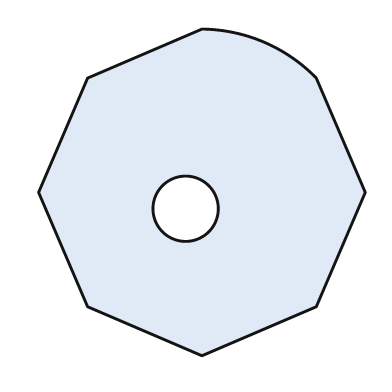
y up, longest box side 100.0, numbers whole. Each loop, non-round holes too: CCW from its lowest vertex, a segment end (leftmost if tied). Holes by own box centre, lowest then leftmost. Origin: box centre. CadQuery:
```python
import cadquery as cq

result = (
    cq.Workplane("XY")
    .moveTo(0.0, -50.0)
    .lineTo(35.0, -35.0)
    .lineTo(50.0, 0.0)
    .lineTo(35.0, 35.0)
    .threePointArc((19.0, 46.0), (0.0, 50.0))
    .lineTo(-35.0, 35.0)
    .lineTo(-50.0, 0.0)
    .lineTo(-35.0, -35.0)
    .close()
    .moveTo(-5.0, -5.0)
    .circle(10.0)
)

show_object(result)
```